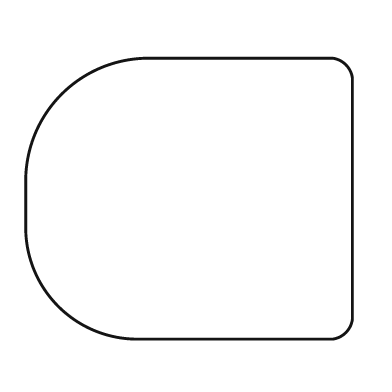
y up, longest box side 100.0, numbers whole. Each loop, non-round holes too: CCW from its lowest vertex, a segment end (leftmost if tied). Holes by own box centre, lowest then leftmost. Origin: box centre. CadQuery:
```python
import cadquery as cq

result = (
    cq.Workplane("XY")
    .moveTo(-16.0, -43.0)
    .lineTo(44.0, -43.0)
    .threePointArc((48.0, -41.0), (50.0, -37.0))
    .lineTo(50.0, 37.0)
    .threePointArc((48.0, 41.0), (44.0, 43.0))
    .lineTo(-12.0, 43.0)
    .threePointArc((-39.0, 32.0), (-50.0, 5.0))
    .lineTo(-50.0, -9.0)
    .threePointArc((-40.0, -33.0), (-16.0, -43.0))
    .close()
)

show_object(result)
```